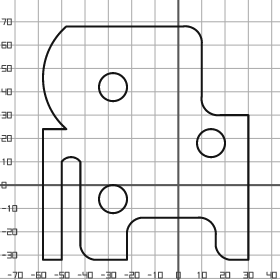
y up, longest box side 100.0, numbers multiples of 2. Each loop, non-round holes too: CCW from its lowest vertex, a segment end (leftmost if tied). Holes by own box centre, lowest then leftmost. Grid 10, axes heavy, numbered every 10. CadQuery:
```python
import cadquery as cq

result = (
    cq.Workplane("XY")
    .moveTo(-58.0, -32.0)
    .lineTo(-50.0, -32.0)
    .lineTo(-50.0, 10.0)
    .threePointArc((-46.0, 12.0), (-42.0, 10.0))
    .lineTo(-42.0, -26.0)
    .threePointArc((-40.0, -30.0), (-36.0, -32.0))
    .lineTo(-22.0, -32.0)
    .lineTo(-22.0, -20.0)
    .threePointArc((-20.0, -16.0), (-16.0, -14.0))
    .lineTo(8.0, -14.0)
    .threePointArc((14.0, -16.0), (16.0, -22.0))
    .lineTo(16.0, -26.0)
    .threePointArc((18.0, -30.0), (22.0, -32.0))
    .lineTo(30.0, -32.0)
    .lineTo(30.0, 30.0)
    .lineTo(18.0, 30.0)
    .threePointArc((12.0, 32.0), (10.0, 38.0))
    .lineTo(10.0, 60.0)
    .threePointArc((8.0, 66.0), (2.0, 68.0))
    .lineTo(-48.0, 68.0)
    .threePointArc((-58.0, 46.0), (-48.0, 24.0))
    .lineTo(-58.0, 24.0)
    .close()
    .moveTo(-28.0, -6.0)
    .circle(6.0)
    .moveTo(14.0, 18.0)
    .circle(6.0)
    .moveTo(-28.0, 42.0)
    .circle(6.0)
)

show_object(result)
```